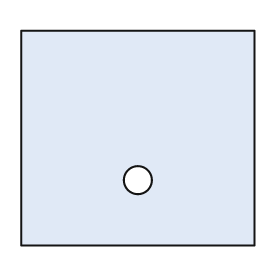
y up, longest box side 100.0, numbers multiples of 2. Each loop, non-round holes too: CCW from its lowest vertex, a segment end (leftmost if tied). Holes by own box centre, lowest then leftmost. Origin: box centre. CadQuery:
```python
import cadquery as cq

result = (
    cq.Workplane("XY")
    .moveTo(-50.0, -46.0)
    .lineTo(50.0, -46.0)
    .lineTo(50.0, 46.0)
    .lineTo(-50.0, 46.0)
    .close()
    .moveTo(0.0, -18.0)
    .circle(6.0)
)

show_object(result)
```